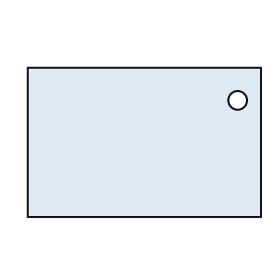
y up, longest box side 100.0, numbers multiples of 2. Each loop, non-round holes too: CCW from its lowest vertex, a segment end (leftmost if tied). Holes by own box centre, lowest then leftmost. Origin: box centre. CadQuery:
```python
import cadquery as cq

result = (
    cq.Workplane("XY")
    .moveTo(-50.0, -32.0)
    .lineTo(50.0, -32.0)
    .lineTo(50.0, 32.0)
    .lineTo(-50.0, 32.0)
    .close()
    .moveTo(40.0, 18.0)
    .circle(4.0)
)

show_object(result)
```